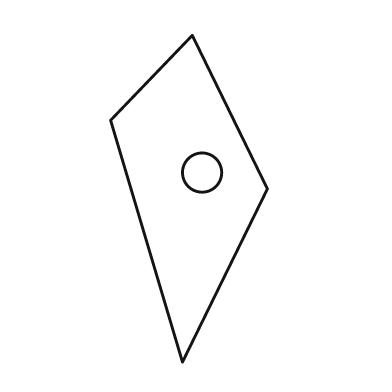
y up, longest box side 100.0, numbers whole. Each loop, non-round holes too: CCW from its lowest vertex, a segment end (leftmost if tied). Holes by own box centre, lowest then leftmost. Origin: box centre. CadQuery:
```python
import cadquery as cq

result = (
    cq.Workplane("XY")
    .moveTo(-2.0, -50.0)
    .lineTo(24.0, 3.0)
    .lineTo(1.0, 50.0)
    .lineTo(-24.0, 24.0)
    .close()
    .moveTo(4.0, 8.0)
    .circle(6.0)
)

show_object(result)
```